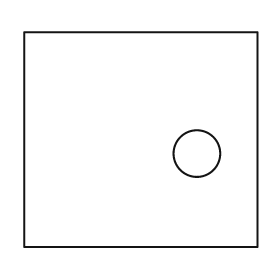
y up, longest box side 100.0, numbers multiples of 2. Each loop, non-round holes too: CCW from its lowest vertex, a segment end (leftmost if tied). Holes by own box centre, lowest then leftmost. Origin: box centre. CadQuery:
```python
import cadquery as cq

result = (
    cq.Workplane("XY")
    .moveTo(-50.0, -46.0)
    .lineTo(50.0, -46.0)
    .lineTo(50.0, 46.0)
    .lineTo(-50.0, 46.0)
    .close()
    .moveTo(24.0, -6.0)
    .circle(10.0)
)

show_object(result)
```